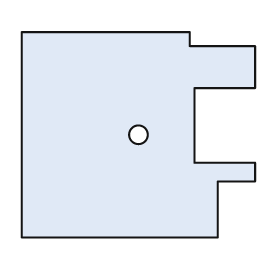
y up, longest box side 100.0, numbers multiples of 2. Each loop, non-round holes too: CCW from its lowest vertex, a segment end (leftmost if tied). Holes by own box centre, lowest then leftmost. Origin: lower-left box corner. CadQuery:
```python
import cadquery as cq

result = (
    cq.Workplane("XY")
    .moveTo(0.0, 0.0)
    .lineTo(84.0, 0.0)
    .lineTo(84.0, 24.0)
    .lineTo(100.0, 24.0)
    .lineTo(100.0, 32.0)
    .lineTo(74.0, 32.0)
    .lineTo(74.0, 64.0)
    .lineTo(100.0, 64.0)
    .lineTo(100.0, 82.0)
    .lineTo(72.0, 82.0)
    .lineTo(72.0, 88.0)
    .lineTo(0.0, 88.0)
    .close()
    .moveTo(50.0, 44.0)
    .circle(4.0)
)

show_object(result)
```